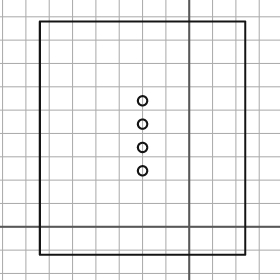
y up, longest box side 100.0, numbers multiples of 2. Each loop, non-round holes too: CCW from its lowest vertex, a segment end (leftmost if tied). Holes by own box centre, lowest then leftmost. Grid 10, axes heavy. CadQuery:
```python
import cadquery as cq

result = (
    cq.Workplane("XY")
    .moveTo(-64.0, -12.0)
    .lineTo(24.0, -12.0)
    .lineTo(24.0, 88.0)
    .lineTo(-64.0, 88.0)
    .close()
    .moveTo(-20.0, 24.0)
    .circle(2.0)
    .moveTo(-20.0, 34.0)
    .circle(2.0)
    .moveTo(-20.0, 44.0)
    .circle(2.0)
    .moveTo(-20.0, 54.0)
    .circle(2.0)
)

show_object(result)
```